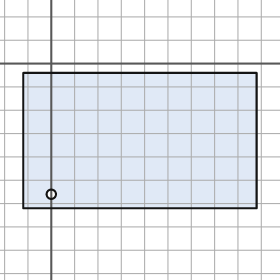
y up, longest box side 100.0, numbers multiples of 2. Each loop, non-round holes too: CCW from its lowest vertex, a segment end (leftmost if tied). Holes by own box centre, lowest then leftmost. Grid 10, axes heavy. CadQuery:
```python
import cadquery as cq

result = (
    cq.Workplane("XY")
    .moveTo(-12.0, -62.0)
    .lineTo(88.0, -62.0)
    .lineTo(88.0, -4.0)
    .lineTo(-12.0, -4.0)
    .close()
    .moveTo(0.0, -56.0)
    .circle(2.0)
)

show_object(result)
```